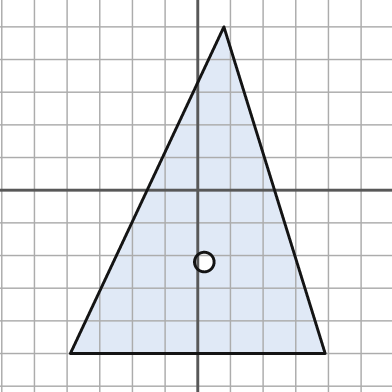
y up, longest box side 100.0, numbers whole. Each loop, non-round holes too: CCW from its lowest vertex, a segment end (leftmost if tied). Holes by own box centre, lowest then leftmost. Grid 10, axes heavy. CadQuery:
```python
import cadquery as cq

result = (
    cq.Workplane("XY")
    .moveTo(-39.0, -50.0)
    .lineTo(39.0, -50.0)
    .lineTo(8.0, 50.0)
    .close()
    .moveTo(2.0, -22.0)
    .circle(3.0)
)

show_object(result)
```